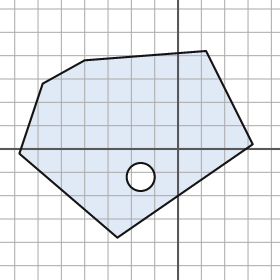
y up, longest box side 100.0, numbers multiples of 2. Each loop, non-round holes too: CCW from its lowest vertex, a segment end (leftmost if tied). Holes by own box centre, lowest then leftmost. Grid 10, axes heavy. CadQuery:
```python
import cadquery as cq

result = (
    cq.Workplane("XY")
    .moveTo(-26.0, -38.0)
    .lineTo(32.0, 2.0)
    .lineTo(12.0, 42.0)
    .lineTo(-40.0, 38.0)
    .lineTo(-58.0, 28.0)
    .lineTo(-68.0, -2.0)
    .close()
    .moveTo(-16.0, -12.0)
    .circle(6.0)
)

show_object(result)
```